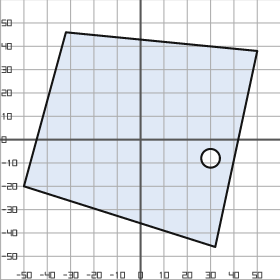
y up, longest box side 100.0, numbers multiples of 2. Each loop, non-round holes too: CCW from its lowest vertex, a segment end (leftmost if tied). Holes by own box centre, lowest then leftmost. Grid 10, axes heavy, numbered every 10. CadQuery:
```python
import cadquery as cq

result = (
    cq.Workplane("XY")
    .moveTo(32.0, -46.0)
    .lineTo(50.0, 38.0)
    .lineTo(-32.0, 46.0)
    .lineTo(-50.0, -20.0)
    .close()
    .moveTo(30.0, -8.0)
    .circle(4.0)
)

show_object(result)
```